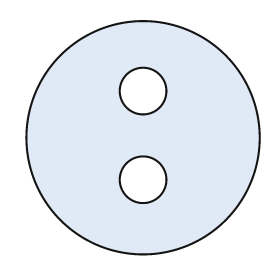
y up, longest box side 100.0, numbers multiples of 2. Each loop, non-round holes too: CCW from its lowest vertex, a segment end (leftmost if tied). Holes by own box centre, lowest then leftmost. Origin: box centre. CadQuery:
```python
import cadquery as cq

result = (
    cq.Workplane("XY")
    .moveTo(0.0, 0.0)
    .circle(50.0)
    .moveTo(0.0, -18.0)
    .circle(10.0)
    .moveTo(0.0, 20.0)
    .circle(10.0)
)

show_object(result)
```